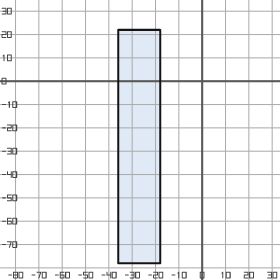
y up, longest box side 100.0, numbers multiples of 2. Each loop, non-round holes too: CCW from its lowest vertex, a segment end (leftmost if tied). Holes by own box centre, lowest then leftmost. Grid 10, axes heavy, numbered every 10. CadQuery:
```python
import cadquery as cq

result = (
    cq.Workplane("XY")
    .moveTo(-36.0, -78.0)
    .lineTo(-18.0, -78.0)
    .lineTo(-18.0, 22.0)
    .lineTo(-36.0, 22.0)
    .close()
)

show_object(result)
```